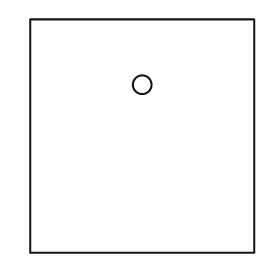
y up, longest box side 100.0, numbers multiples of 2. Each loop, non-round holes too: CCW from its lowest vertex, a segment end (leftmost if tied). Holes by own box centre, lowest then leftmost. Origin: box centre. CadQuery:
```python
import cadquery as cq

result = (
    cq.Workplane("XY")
    .moveTo(-48.0, -50.0)
    .lineTo(48.0, -50.0)
    .lineTo(48.0, 50.0)
    .lineTo(-48.0, 50.0)
    .close()
    .moveTo(0.0, 22.0)
    .circle(4.0)
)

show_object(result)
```